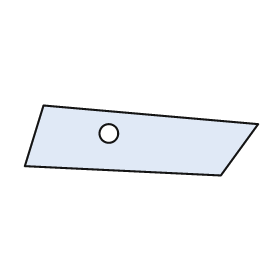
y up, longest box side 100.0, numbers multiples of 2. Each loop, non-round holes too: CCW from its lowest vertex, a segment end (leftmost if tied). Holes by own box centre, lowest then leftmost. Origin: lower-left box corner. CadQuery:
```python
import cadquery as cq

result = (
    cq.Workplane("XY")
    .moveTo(84.0, 0.0)
    .lineTo(100.0, 22.0)
    .lineTo(8.0, 30.0)
    .lineTo(0.0, 4.0)
    .close()
    .moveTo(36.0, 18.0)
    .circle(4.0)
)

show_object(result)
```